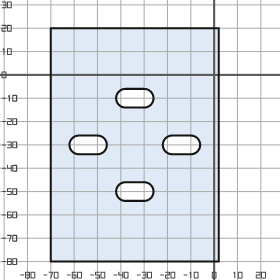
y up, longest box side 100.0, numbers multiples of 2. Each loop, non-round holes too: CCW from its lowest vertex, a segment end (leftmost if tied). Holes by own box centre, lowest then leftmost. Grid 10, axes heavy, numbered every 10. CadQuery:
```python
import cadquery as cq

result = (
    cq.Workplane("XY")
    .moveTo(-70.0, -80.0)
    .lineTo(2.0, -80.0)
    .lineTo(2.0, 20.0)
    .lineTo(-70.0, 20.0)
    .close()
    .moveTo(-38.0, -54.0)
    .lineTo(-30.0, -54.0)
    .threePointArc((-26.0, -50.0), (-30.0, -46.0))
    .lineTo(-38.0, -46.0)
    .threePointArc((-42.0, -50.0), (-38.0, -54.0))
    .close()
    .moveTo(-58.0, -34.0)
    .lineTo(-50.0, -34.0)
    .threePointArc((-46.0, -30.0), (-50.0, -26.0))
    .lineTo(-58.0, -26.0)
    .threePointArc((-62.0, -30.0), (-58.0, -34.0))
    .close()
    .moveTo(-18.0, -34.0)
    .lineTo(-10.0, -34.0)
    .threePointArc((-6.0, -30.0), (-10.0, -26.0))
    .lineTo(-18.0, -26.0)
    .threePointArc((-22.0, -30.0), (-18.0, -34.0))
    .close()
    .moveTo(-38.0, -14.0)
    .lineTo(-30.0, -14.0)
    .threePointArc((-26.0, -10.0), (-30.0, -6.0))
    .lineTo(-38.0, -6.0)
    .threePointArc((-42.0, -10.0), (-38.0, -14.0))
    .close()
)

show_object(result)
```